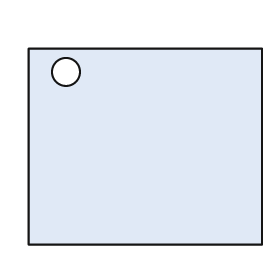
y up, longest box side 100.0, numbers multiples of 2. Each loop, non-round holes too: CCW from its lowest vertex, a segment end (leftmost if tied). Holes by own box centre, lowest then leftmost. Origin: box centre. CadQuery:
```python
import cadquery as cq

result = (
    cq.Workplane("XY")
    .moveTo(-50.0, -42.0)
    .lineTo(50.0, -42.0)
    .lineTo(50.0, 42.0)
    .lineTo(-50.0, 42.0)
    .close()
    .moveTo(-34.0, 32.0)
    .circle(6.0)
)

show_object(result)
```